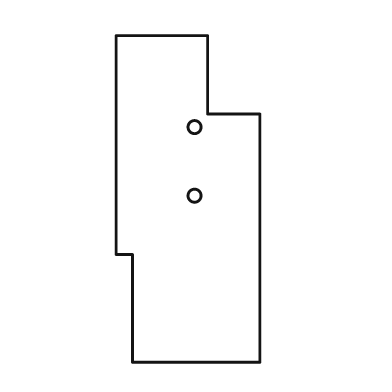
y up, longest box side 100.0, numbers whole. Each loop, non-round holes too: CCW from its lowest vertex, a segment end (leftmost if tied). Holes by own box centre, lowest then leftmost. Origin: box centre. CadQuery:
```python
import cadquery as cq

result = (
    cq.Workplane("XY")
    .moveTo(-17.0, -50.0)
    .lineTo(22.0, -50.0)
    .lineTo(22.0, 26.0)
    .lineTo(6.0, 26.0)
    .lineTo(6.0, 50.0)
    .lineTo(-22.0, 50.0)
    .lineTo(-22.0, -17.0)
    .lineTo(-17.0, -17.0)
    .close()
    .moveTo(2.0, 1.0)
    .circle(2.0)
    .moveTo(2.0, 22.0)
    .circle(2.0)
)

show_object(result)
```